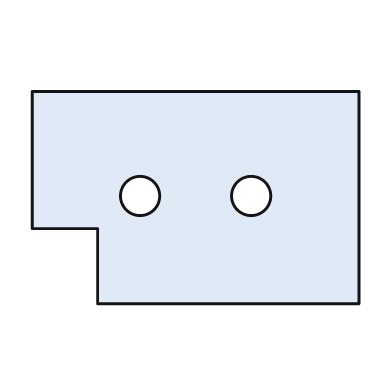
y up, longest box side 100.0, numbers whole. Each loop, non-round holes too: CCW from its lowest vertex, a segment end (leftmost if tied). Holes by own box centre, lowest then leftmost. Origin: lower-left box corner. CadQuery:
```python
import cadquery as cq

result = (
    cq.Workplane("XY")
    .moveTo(20.0, 0.0)
    .lineTo(100.0, 0.0)
    .lineTo(100.0, 65.0)
    .lineTo(0.0, 65.0)
    .lineTo(0.0, 23.0)
    .lineTo(20.0, 23.0)
    .close()
    .moveTo(33.0, 33.0)
    .circle(6.0)
    .moveTo(67.0, 33.0)
    .circle(6.0)
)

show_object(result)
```